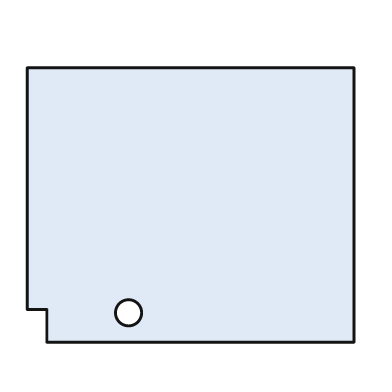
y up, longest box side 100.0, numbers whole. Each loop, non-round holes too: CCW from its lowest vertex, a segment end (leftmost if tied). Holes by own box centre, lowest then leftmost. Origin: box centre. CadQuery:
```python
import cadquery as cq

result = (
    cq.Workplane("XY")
    .moveTo(-44.0, -42.0)
    .lineTo(50.0, -42.0)
    .lineTo(50.0, 42.0)
    .lineTo(-50.0, 42.0)
    .lineTo(-50.0, -32.0)
    .lineTo(-44.0, -32.0)
    .close()
    .moveTo(-19.0, -33.0)
    .circle(4.0)
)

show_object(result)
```